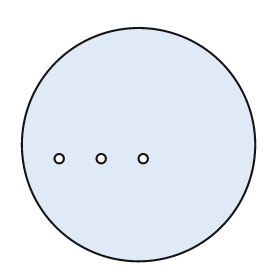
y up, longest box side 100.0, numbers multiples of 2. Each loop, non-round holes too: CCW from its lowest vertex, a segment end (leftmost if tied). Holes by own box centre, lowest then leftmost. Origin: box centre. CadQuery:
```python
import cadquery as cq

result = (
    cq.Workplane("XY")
    .moveTo(0.0, 0.0)
    .circle(50.0)
    .moveTo(-34.0, -6.0)
    .circle(2.0)
    .moveTo(-16.0, -6.0)
    .circle(2.0)
    .moveTo(2.0, -6.0)
    .circle(2.0)
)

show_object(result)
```